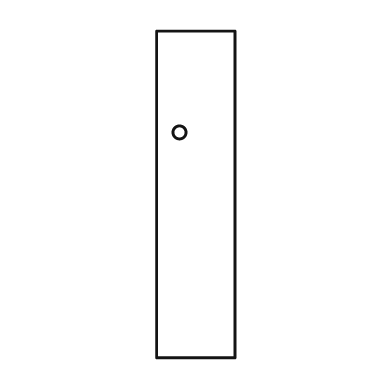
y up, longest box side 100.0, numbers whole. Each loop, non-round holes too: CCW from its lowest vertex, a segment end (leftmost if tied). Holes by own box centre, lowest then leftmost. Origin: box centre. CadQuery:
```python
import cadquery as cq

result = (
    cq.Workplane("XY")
    .moveTo(-12.0, -50.0)
    .lineTo(12.0, -50.0)
    .lineTo(12.0, 50.0)
    .lineTo(-12.0, 50.0)
    .close()
    .moveTo(-5.0, 19.0)
    .circle(2.0)
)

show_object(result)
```